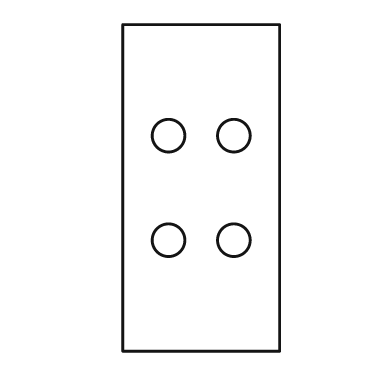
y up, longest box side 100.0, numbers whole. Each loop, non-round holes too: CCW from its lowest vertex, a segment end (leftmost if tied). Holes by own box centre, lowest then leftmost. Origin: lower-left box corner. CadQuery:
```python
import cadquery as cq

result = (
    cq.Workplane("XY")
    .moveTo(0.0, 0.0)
    .lineTo(48.0, 0.0)
    .lineTo(48.0, 100.0)
    .lineTo(0.0, 100.0)
    .close()
    .moveTo(14.0, 34.0)
    .circle(5.0)
    .moveTo(34.0, 34.0)
    .circle(5.0)
    .moveTo(14.0, 66.0)
    .circle(5.0)
    .moveTo(34.0, 66.0)
    .circle(5.0)
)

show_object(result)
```